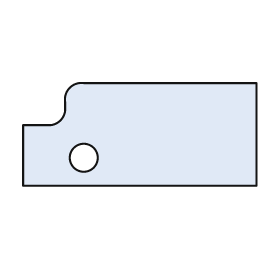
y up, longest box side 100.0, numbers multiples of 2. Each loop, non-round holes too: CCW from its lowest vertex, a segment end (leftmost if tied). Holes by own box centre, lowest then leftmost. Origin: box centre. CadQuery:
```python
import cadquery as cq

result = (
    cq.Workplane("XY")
    .moveTo(-50.0, -22.0)
    .lineTo(50.0, -22.0)
    .lineTo(50.0, 22.0)
    .lineTo(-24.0, 22.0)
    .threePointArc((-30.0, 20.0), (-32.0, 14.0))
    .lineTo(-32.0, 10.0)
    .threePointArc((-34.0, 6.0), (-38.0, 4.0))
    .lineTo(-50.0, 4.0)
    .close()
    .moveTo(-24.0, -10.0)
    .circle(6.0)
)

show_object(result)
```